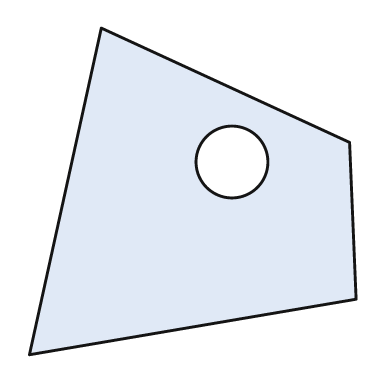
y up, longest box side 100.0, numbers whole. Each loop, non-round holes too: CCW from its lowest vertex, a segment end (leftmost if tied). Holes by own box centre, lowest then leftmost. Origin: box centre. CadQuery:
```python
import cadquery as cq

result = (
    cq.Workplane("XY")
    .moveTo(-50.0, -50.0)
    .lineTo(50.0, -33.0)
    .lineTo(48.0, 15.0)
    .lineTo(-28.0, 50.0)
    .close()
    .moveTo(12.0, 9.0)
    .circle(11.0)
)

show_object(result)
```